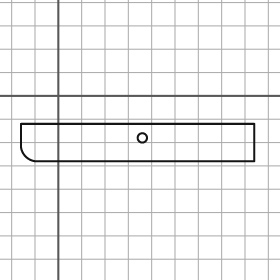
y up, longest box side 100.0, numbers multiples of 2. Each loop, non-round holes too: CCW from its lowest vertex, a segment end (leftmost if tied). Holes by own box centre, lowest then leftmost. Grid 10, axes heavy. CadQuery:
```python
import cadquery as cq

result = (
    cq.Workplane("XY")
    .moveTo(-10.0, -28.0)
    .lineTo(84.0, -28.0)
    .lineTo(84.0, -12.0)
    .lineTo(-16.0, -12.0)
    .lineTo(-16.0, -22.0)
    .threePointArc((-14.0, -26.0), (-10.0, -28.0))
    .close()
    .moveTo(36.0, -18.0)
    .circle(2.0)
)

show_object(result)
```